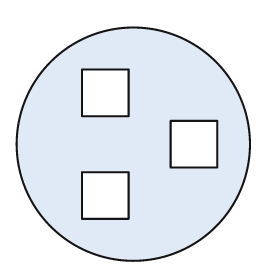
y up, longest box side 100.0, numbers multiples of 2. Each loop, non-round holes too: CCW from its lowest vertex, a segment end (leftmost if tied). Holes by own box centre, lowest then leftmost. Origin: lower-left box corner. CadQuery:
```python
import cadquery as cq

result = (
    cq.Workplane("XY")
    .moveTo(50.0, 50.0)
    .circle(50.0)
    .moveTo(28.0, 18.0)
    .lineTo(48.0, 18.0)
    .lineTo(48.0, 38.0)
    .lineTo(28.0, 38.0)
    .close()
    .moveTo(66.0, 40.0)
    .lineTo(86.0, 40.0)
    .lineTo(86.0, 60.0)
    .lineTo(66.0, 60.0)
    .close()
    .moveTo(28.0, 62.0)
    .lineTo(48.0, 62.0)
    .lineTo(48.0, 82.0)
    .lineTo(28.0, 82.0)
    .close()
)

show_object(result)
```